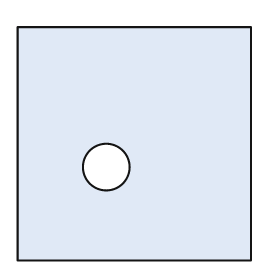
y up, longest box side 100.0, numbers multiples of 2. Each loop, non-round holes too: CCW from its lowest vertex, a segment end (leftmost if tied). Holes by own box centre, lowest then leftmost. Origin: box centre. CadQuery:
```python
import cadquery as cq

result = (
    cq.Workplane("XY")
    .moveTo(-50.0, -50.0)
    .lineTo(50.0, -50.0)
    .lineTo(50.0, 50.0)
    .lineTo(-50.0, 50.0)
    .close()
    .moveTo(-12.0, -10.0)
    .circle(10.0)
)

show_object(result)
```